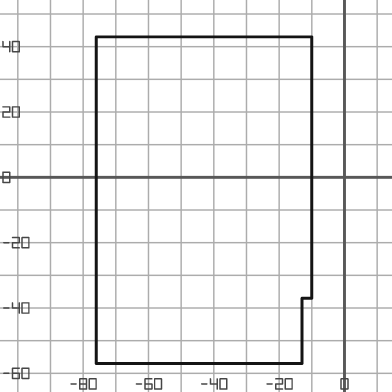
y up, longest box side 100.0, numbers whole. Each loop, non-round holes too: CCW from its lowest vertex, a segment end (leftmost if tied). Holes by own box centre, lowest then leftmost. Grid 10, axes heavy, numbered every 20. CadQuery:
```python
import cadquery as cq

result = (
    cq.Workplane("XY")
    .moveTo(-76.0, -57.0)
    .lineTo(-13.0, -57.0)
    .lineTo(-13.0, -37.0)
    .lineTo(-10.0, -37.0)
    .lineTo(-10.0, 43.0)
    .lineTo(-76.0, 43.0)
    .close()
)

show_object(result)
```